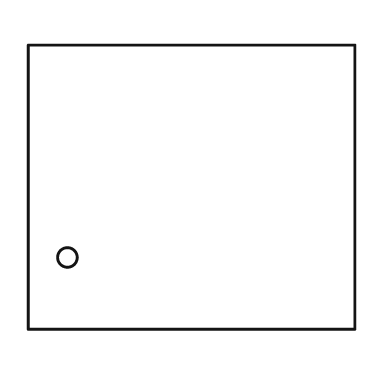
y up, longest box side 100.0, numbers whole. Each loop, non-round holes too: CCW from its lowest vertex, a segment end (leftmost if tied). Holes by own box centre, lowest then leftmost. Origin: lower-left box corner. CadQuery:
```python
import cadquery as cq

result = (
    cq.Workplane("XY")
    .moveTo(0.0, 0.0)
    .lineTo(100.0, 0.0)
    .lineTo(100.0, 87.0)
    .lineTo(0.0, 87.0)
    .close()
    .moveTo(12.0, 22.0)
    .circle(3.0)
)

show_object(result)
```